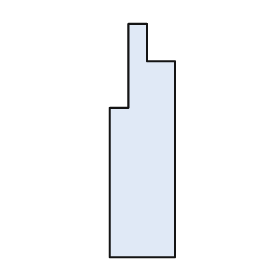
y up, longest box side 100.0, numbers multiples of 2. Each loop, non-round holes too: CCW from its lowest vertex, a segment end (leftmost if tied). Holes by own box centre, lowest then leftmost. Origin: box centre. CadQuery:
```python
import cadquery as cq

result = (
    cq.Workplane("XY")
    .moveTo(-14.0, -50.0)
    .lineTo(14.0, -50.0)
    .lineTo(14.0, 34.0)
    .lineTo(2.0, 34.0)
    .lineTo(2.0, 50.0)
    .lineTo(-6.0, 50.0)
    .lineTo(-6.0, 14.0)
    .lineTo(-14.0, 14.0)
    .close()
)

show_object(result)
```